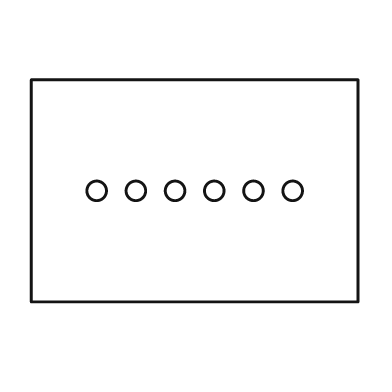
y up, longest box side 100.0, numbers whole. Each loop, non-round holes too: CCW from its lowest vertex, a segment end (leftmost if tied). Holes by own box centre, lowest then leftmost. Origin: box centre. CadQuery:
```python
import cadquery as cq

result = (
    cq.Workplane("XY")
    .moveTo(-50.0, -34.0)
    .lineTo(50.0, -34.0)
    .lineTo(50.0, 34.0)
    .lineTo(-50.0, 34.0)
    .close()
    .moveTo(-30.0, 0.0)
    .circle(3.0)
    .moveTo(-18.0, 0.0)
    .circle(3.0)
    .moveTo(-6.0, 0.0)
    .circle(3.0)
    .moveTo(6.0, 0.0)
    .circle(3.0)
    .moveTo(18.0, 0.0)
    .circle(3.0)
    .moveTo(30.0, 0.0)
    .circle(3.0)
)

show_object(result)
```